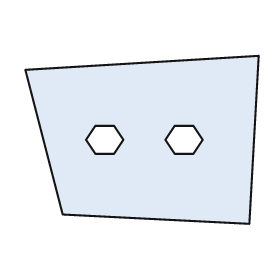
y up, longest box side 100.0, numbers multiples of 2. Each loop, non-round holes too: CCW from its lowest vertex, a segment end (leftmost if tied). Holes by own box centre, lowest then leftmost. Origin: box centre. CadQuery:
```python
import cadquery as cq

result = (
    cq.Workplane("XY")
    .moveTo(46.0, -36.0)
    .lineTo(50.0, 36.0)
    .lineTo(-50.0, 30.0)
    .lineTo(-34.0, -32.0)
    .close()
    .moveTo(-20.0, -6.0)
    .lineTo(-12.0, -6.0)
    .lineTo(-8.0, 0.0)
    .lineTo(-12.0, 6.0)
    .lineTo(-20.0, 6.0)
    .lineTo(-24.0, 0.0)
    .close()
    .moveTo(14.0, -6.0)
    .lineTo(22.0, -6.0)
    .lineTo(26.0, 0.0)
    .lineTo(22.0, 6.0)
    .lineTo(14.0, 6.0)
    .lineTo(10.0, 0.0)
    .close()
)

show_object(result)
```